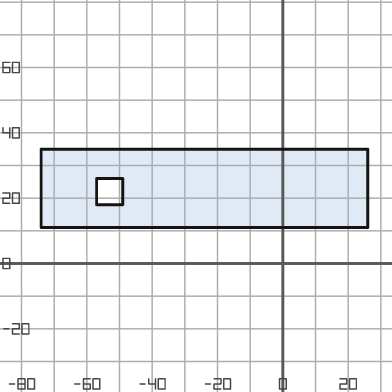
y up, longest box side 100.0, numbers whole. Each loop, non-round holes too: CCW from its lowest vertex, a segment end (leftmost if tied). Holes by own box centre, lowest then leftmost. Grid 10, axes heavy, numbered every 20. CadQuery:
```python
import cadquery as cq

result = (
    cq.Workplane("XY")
    .moveTo(-74.0, 11.0)
    .lineTo(26.0, 11.0)
    .lineTo(26.0, 35.0)
    .lineTo(-74.0, 35.0)
    .close()
    .moveTo(-57.0, 18.0)
    .lineTo(-49.0, 18.0)
    .lineTo(-49.0, 26.0)
    .lineTo(-57.0, 26.0)
    .close()
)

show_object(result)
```